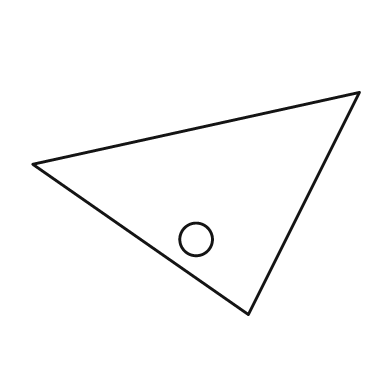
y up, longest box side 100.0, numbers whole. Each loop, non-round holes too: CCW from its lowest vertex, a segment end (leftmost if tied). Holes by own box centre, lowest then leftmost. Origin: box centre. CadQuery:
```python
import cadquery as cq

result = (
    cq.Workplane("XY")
    .moveTo(16.0, -34.0)
    .lineTo(50.0, 34.0)
    .lineTo(-50.0, 12.0)
    .close()
    .moveTo(0.0, -11.0)
    .circle(5.0)
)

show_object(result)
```